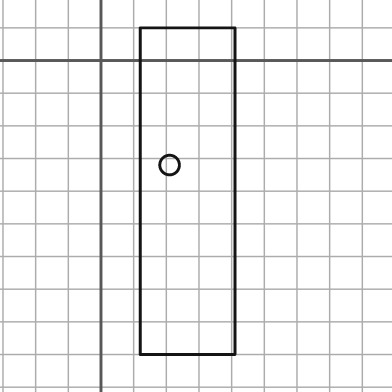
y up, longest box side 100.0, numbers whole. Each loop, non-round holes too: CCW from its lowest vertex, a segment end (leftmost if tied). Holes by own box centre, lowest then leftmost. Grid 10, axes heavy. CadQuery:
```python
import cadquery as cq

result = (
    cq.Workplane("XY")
    .moveTo(12.0, -90.0)
    .lineTo(41.0, -90.0)
    .lineTo(41.0, 10.0)
    .lineTo(12.0, 10.0)
    .close()
    .moveTo(21.0, -32.0)
    .circle(3.0)
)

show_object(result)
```